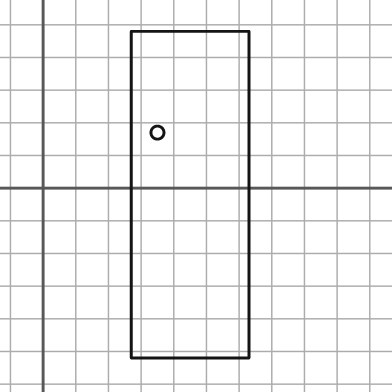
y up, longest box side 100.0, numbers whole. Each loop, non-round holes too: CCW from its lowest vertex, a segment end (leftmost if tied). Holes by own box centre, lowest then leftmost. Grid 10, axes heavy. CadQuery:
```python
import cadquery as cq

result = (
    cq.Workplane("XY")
    .moveTo(27.0, -52.0)
    .lineTo(63.0, -52.0)
    .lineTo(63.0, 48.0)
    .lineTo(27.0, 48.0)
    .close()
    .moveTo(35.0, 17.0)
    .circle(2.0)
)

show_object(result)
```